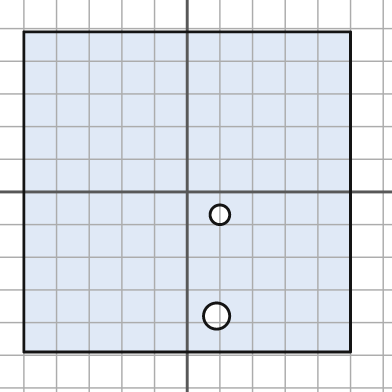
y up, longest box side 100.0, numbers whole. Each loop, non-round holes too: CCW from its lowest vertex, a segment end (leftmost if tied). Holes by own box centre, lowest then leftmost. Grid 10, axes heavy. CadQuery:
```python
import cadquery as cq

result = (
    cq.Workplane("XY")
    .moveTo(-50.0, -49.0)
    .lineTo(50.0, -49.0)
    .lineTo(50.0, 49.0)
    .lineTo(-50.0, 49.0)
    .close()
    .moveTo(9.0, -38.0)
    .circle(4.0)
    .moveTo(10.0, -7.0)
    .circle(3.0)
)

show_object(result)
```